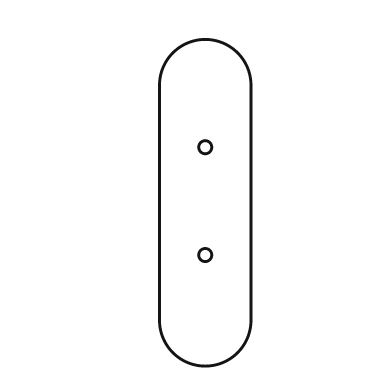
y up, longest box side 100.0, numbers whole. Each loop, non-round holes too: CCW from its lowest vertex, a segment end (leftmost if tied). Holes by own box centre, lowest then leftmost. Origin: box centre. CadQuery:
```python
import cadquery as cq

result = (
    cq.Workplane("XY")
    .moveTo(-14.0, -36.0)
    .threePointArc((0.0, -50.0), (14.0, -36.0))
    .lineTo(14.0, 36.0)
    .threePointArc((0.0, 50.0), (-14.0, 36.0))
    .close()
    .moveTo(0.0, -16.0)
    .circle(2.0)
    .moveTo(0.0, 17.0)
    .circle(2.0)
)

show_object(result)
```